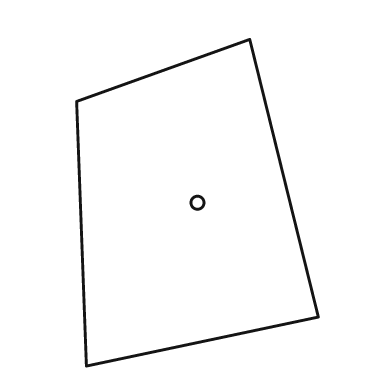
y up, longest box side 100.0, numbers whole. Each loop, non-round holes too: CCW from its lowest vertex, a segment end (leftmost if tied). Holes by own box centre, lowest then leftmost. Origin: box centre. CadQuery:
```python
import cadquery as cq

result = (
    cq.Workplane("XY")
    .moveTo(-34.0, -50.0)
    .lineTo(37.0, -35.0)
    .lineTo(16.0, 50.0)
    .lineTo(-37.0, 31.0)
    .close()
    .moveTo(0.0, 0.0)
    .circle(2.0)
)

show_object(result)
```